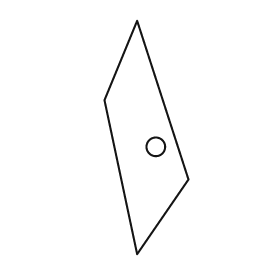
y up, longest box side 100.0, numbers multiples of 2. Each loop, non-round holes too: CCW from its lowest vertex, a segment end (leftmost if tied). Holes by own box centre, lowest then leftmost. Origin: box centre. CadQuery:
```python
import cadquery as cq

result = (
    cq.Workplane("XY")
    .moveTo(-4.0, -50.0)
    .lineTo(18.0, -18.0)
    .lineTo(-4.0, 50.0)
    .lineTo(-18.0, 16.0)
    .close()
    .moveTo(4.0, -4.0)
    .circle(4.0)
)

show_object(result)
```